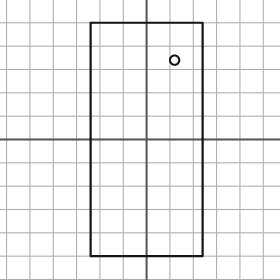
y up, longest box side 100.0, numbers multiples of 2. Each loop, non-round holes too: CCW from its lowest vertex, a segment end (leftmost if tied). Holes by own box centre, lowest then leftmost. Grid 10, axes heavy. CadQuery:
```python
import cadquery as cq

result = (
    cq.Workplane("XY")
    .moveTo(-24.0, -50.0)
    .lineTo(24.0, -50.0)
    .lineTo(24.0, 50.0)
    .lineTo(-24.0, 50.0)
    .close()
    .moveTo(12.0, 34.0)
    .circle(2.0)
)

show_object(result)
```